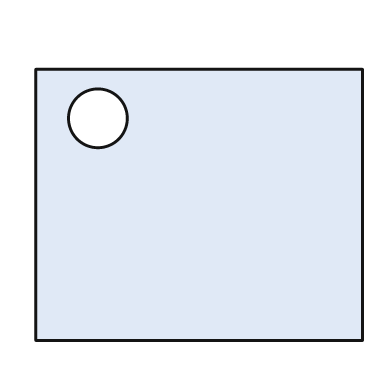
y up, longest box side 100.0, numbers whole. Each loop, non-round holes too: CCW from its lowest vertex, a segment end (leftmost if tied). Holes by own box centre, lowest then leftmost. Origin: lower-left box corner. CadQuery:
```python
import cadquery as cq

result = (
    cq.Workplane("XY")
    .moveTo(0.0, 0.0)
    .lineTo(100.0, 0.0)
    .lineTo(100.0, 83.0)
    .lineTo(0.0, 83.0)
    .close()
    .moveTo(19.0, 68.0)
    .circle(9.0)
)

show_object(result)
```